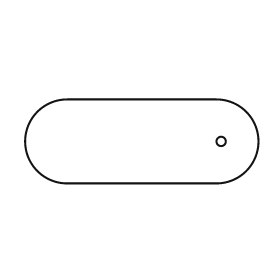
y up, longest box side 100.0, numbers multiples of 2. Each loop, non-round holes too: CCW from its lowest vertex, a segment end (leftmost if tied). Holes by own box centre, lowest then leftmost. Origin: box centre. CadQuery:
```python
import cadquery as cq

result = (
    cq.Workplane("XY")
    .moveTo(-32.0, -18.0)
    .lineTo(32.0, -18.0)
    .threePointArc((50.0, 0.0), (32.0, 18.0))
    .lineTo(-32.0, 18.0)
    .threePointArc((-50.0, 0.0), (-32.0, -18.0))
    .close()
    .moveTo(34.0, 0.0)
    .circle(2.0)
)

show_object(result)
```